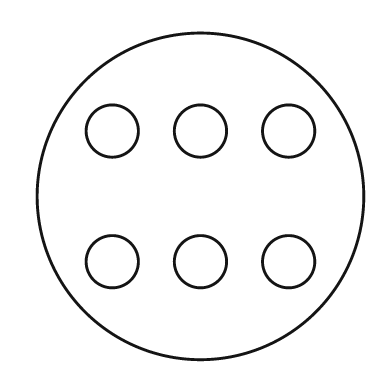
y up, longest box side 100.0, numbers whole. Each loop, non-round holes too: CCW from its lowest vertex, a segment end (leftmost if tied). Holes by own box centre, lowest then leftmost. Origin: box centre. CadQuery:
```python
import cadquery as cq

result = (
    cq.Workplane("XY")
    .moveTo(0.0, 0.0)
    .circle(50.0)
    .moveTo(-27.0, -20.0)
    .circle(8.0)
    .moveTo(0.0, -20.0)
    .circle(8.0)
    .moveTo(27.0, -20.0)
    .circle(8.0)
    .moveTo(-27.0, 20.0)
    .circle(8.0)
    .moveTo(0.0, 20.0)
    .circle(8.0)
    .moveTo(27.0, 20.0)
    .circle(8.0)
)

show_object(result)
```